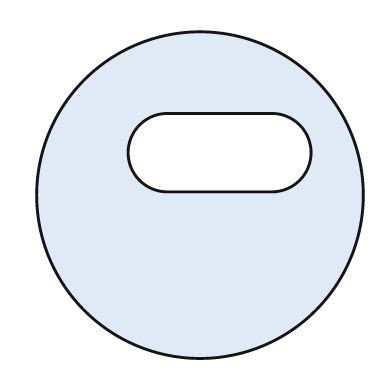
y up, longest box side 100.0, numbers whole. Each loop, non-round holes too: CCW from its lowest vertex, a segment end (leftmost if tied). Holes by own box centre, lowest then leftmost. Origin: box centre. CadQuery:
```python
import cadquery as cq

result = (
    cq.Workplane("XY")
    .moveTo(0.0, 0.0)
    .circle(50.0)
    .moveTo(-10.0, 1.0)
    .lineTo(22.0, 1.0)
    .threePointArc((34.0, 13.0), (22.0, 25.0))
    .lineTo(-10.0, 25.0)
    .threePointArc((-22.0, 13.0), (-10.0, 1.0))
    .close()
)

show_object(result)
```